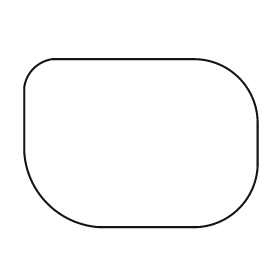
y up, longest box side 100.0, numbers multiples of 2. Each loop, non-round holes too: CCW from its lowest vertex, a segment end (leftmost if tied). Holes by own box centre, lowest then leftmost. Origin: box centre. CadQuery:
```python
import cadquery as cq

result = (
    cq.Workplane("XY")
    .moveTo(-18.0, -36.0)
    .lineTo(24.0, -36.0)
    .threePointArc((42.0, -28.0), (50.0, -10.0))
    .lineTo(50.0, 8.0)
    .threePointArc((42.0, 28.0), (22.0, 36.0))
    .lineTo(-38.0, 36.0)
    .threePointArc((-46.0, 32.0), (-50.0, 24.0))
    .lineTo(-50.0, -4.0)
    .threePointArc((-40.0, -26.0), (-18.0, -36.0))
    .close()
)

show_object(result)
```